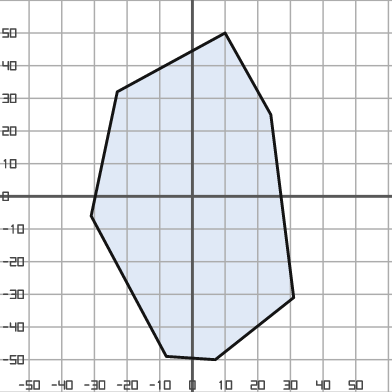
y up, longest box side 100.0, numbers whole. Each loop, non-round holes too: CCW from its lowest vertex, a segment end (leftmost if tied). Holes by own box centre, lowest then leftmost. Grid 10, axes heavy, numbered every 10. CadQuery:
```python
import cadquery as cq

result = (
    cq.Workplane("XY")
    .moveTo(7.0, -50.0)
    .lineTo(31.0, -31.0)
    .lineTo(24.0, 25.0)
    .lineTo(10.0, 50.0)
    .lineTo(-23.0, 32.0)
    .lineTo(-31.0, -6.0)
    .lineTo(-8.0, -49.0)
    .close()
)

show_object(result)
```